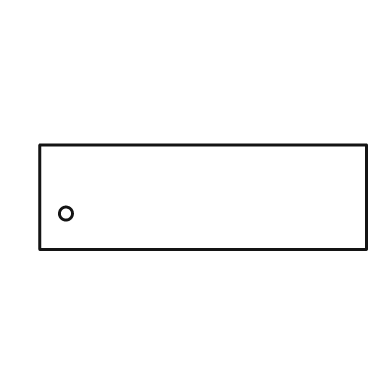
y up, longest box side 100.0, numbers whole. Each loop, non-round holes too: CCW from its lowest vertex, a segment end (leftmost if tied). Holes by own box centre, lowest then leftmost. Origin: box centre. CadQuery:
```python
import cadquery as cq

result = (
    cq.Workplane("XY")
    .moveTo(-50.0, -16.0)
    .lineTo(50.0, -16.0)
    .lineTo(50.0, 16.0)
    .lineTo(-50.0, 16.0)
    .close()
    .moveTo(-42.0, -5.0)
    .circle(2.0)
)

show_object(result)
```